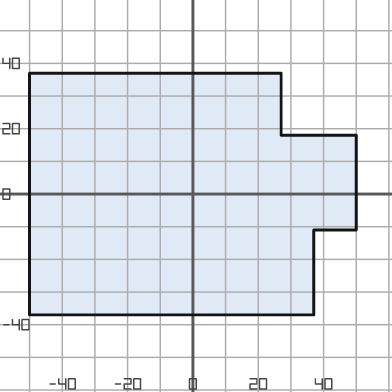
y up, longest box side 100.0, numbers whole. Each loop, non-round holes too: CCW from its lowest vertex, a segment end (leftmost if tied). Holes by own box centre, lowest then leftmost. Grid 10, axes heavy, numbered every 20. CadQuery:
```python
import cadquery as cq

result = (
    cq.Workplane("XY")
    .moveTo(-50.0, -37.0)
    .lineTo(37.0, -37.0)
    .lineTo(37.0, -11.0)
    .lineTo(50.0, -11.0)
    .lineTo(50.0, 18.0)
    .lineTo(27.0, 18.0)
    .lineTo(27.0, 37.0)
    .lineTo(-50.0, 37.0)
    .close()
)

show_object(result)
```